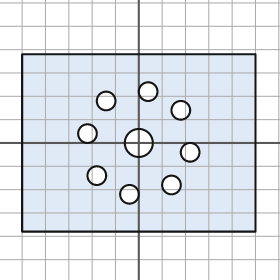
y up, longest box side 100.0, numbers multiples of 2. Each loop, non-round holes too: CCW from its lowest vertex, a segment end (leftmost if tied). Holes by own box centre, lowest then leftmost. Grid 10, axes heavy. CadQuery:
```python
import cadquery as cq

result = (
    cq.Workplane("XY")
    .moveTo(-50.0, -38.0)
    .lineTo(50.0, -38.0)
    .lineTo(50.0, 38.0)
    .lineTo(-50.0, 38.0)
    .close()
    .moveTo(-4.0, -22.0)
    .circle(4.0)
    .moveTo(14.0, -18.0)
    .circle(4.0)
    .moveTo(-18.0, -14.0)
    .circle(4.0)
    .moveTo(22.0, -4.0)
    .circle(4.0)
    .moveTo(0.0, 0.0)
    .circle(6.0)
    .moveTo(-22.0, 4.0)
    .circle(4.0)
    .moveTo(18.0, 14.0)
    .circle(4.0)
    .moveTo(-14.0, 18.0)
    .circle(4.0)
    .moveTo(4.0, 22.0)
    .circle(4.0)
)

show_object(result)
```